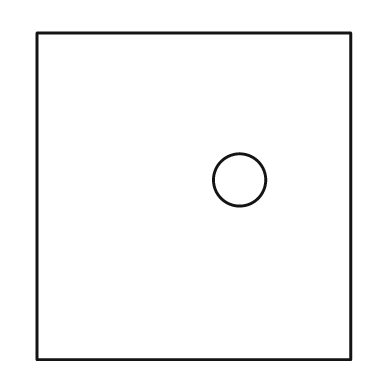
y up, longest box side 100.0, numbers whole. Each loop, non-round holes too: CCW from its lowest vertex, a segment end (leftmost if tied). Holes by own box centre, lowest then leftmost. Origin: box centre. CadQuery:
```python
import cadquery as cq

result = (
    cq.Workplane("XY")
    .moveTo(-48.0, -50.0)
    .lineTo(48.0, -50.0)
    .lineTo(48.0, 50.0)
    .lineTo(-48.0, 50.0)
    .close()
    .moveTo(14.0, 5.0)
    .circle(8.0)
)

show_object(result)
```